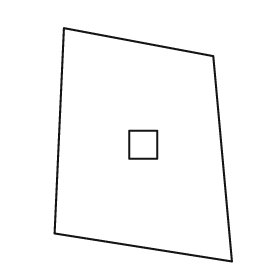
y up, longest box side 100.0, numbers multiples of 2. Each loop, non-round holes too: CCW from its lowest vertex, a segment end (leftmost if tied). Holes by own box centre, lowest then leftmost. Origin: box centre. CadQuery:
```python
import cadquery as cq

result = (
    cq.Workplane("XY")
    .moveTo(38.0, -50.0)
    .lineTo(30.0, 38.0)
    .lineTo(-34.0, 50.0)
    .lineTo(-38.0, -38.0)
    .close()
    .moveTo(-6.0, -6.0)
    .lineTo(6.0, -6.0)
    .lineTo(6.0, 6.0)
    .lineTo(-6.0, 6.0)
    .close()
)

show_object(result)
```